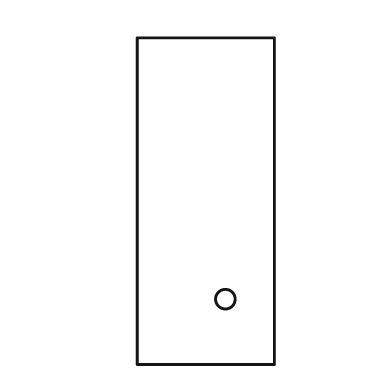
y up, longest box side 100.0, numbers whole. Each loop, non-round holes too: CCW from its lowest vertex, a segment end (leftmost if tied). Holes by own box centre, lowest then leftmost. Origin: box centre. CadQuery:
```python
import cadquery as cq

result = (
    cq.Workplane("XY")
    .moveTo(-21.0, -50.0)
    .lineTo(21.0, -50.0)
    .lineTo(21.0, 50.0)
    .lineTo(-21.0, 50.0)
    .close()
    .moveTo(6.0, -30.0)
    .circle(3.0)
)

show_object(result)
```